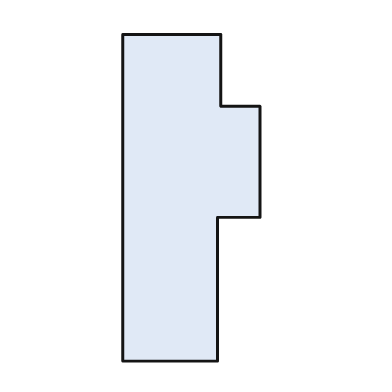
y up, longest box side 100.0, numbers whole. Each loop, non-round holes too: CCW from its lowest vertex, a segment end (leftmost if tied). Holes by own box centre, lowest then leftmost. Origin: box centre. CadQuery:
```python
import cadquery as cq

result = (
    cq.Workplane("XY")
    .moveTo(-21.0, -50.0)
    .lineTo(8.0, -50.0)
    .lineTo(8.0, -6.0)
    .lineTo(21.0, -6.0)
    .lineTo(21.0, 28.0)
    .lineTo(9.0, 28.0)
    .lineTo(9.0, 50.0)
    .lineTo(-21.0, 50.0)
    .close()
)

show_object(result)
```